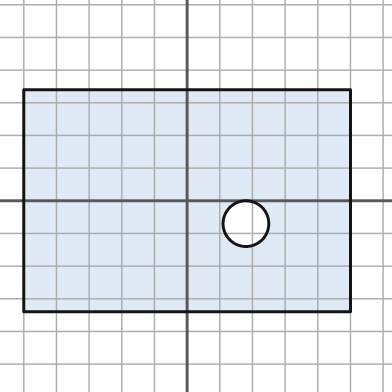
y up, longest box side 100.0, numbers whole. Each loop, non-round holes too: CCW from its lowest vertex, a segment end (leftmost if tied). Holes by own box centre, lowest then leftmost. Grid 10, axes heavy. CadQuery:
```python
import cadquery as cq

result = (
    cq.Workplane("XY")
    .moveTo(-50.0, -34.0)
    .lineTo(50.0, -34.0)
    .lineTo(50.0, 34.0)
    .lineTo(-50.0, 34.0)
    .close()
    .moveTo(18.0, -7.0)
    .circle(7.0)
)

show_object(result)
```